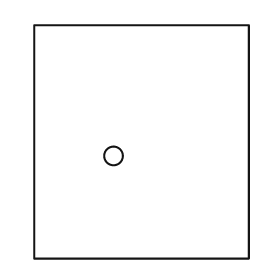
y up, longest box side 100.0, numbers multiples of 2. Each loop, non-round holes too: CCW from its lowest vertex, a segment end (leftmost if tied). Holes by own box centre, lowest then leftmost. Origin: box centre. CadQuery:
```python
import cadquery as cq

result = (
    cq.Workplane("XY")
    .moveTo(-46.0, -50.0)
    .lineTo(46.0, -50.0)
    .lineTo(46.0, 50.0)
    .lineTo(-46.0, 50.0)
    .close()
    .moveTo(-12.0, -6.0)
    .circle(4.0)
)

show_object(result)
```